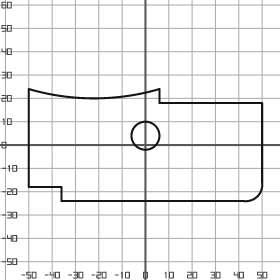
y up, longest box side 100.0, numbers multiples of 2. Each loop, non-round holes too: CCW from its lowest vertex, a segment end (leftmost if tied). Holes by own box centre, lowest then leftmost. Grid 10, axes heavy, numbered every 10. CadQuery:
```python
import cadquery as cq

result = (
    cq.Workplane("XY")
    .moveTo(-36.0, -24.0)
    .lineTo(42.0, -24.0)
    .threePointArc((48.0, -22.0), (50.0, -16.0))
    .lineTo(50.0, 18.0)
    .lineTo(6.0, 18.0)
    .lineTo(6.0, 24.0)
    .threePointArc((-22.0, 20.0), (-50.0, 24.0))
    .lineTo(-50.0, -18.0)
    .lineTo(-36.0, -18.0)
    .close()
    .moveTo(0.0, 4.0)
    .circle(6.0)
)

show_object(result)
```